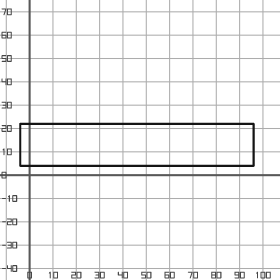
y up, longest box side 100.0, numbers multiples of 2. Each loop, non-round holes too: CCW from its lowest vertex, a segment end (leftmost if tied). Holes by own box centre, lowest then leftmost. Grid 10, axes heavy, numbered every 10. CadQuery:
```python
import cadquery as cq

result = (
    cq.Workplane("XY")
    .moveTo(-4.0, 4.0)
    .lineTo(96.0, 4.0)
    .lineTo(96.0, 22.0)
    .lineTo(-4.0, 22.0)
    .close()
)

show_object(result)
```